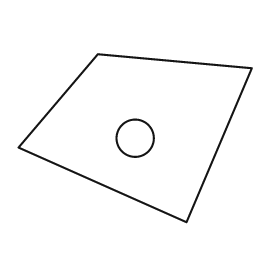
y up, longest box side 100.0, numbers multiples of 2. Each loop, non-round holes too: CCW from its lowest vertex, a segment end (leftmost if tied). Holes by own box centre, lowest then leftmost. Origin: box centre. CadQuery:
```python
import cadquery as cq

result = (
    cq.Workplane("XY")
    .moveTo(22.0, -36.0)
    .lineTo(50.0, 30.0)
    .lineTo(-16.0, 36.0)
    .lineTo(-50.0, -4.0)
    .close()
    .moveTo(0.0, 0.0)
    .circle(8.0)
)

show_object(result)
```